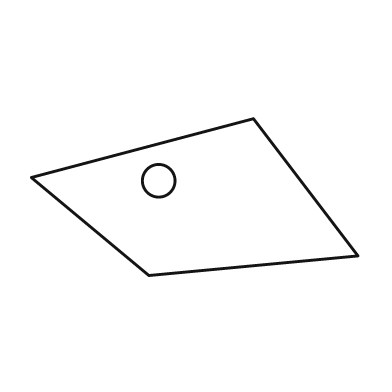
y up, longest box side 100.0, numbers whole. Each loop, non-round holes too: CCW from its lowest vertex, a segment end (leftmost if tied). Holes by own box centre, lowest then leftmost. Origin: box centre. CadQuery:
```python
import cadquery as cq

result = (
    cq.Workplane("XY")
    .moveTo(-14.0, -24.0)
    .lineTo(50.0, -18.0)
    .lineTo(18.0, 24.0)
    .lineTo(-50.0, 6.0)
    .close()
    .moveTo(-11.0, 5.0)
    .circle(5.0)
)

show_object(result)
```